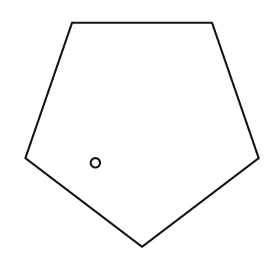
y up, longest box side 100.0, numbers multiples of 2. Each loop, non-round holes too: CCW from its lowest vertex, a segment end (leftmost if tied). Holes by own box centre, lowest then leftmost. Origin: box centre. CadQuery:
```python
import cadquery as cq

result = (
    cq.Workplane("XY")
    .moveTo(0.0, -48.0)
    .lineTo(50.0, -10.0)
    .lineTo(30.0, 48.0)
    .lineTo(-30.0, 48.0)
    .lineTo(-50.0, -10.0)
    .close()
    .moveTo(-20.0, -12.0)
    .circle(2.0)
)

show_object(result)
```